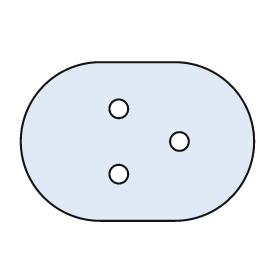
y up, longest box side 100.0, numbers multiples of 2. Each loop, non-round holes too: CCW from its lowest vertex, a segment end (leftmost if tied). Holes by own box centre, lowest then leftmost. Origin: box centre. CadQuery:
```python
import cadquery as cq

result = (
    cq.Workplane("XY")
    .moveTo(-16.0, -34.0)
    .lineTo(16.0, -34.0)
    .threePointArc((50.0, 0.0), (16.0, 34.0))
    .lineTo(-16.0, 34.0)
    .threePointArc((-50.0, 0.0), (-16.0, -34.0))
    .close()
    .moveTo(-8.0, -14.0)
    .circle(4.0)
    .moveTo(18.0, 0.0)
    .circle(4.0)
    .moveTo(-8.0, 14.0)
    .circle(4.0)
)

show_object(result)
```